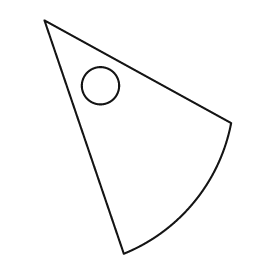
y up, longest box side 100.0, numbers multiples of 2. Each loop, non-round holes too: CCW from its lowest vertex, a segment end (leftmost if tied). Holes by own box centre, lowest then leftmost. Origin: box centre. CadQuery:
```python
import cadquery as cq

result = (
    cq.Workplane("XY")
    .moveTo(-6.0, -50.0)
    .threePointArc((24.0, -28.0), (40.0, 6.0))
    .lineTo(-40.0, 50.0)
    .close()
    .moveTo(-16.0, 22.0)
    .circle(8.0)
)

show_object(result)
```